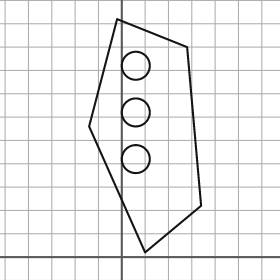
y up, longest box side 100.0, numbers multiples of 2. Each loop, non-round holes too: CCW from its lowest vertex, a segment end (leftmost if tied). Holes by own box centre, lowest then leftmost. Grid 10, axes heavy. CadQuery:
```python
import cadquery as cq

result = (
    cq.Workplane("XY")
    .moveTo(10.0, 2.0)
    .lineTo(34.0, 22.0)
    .lineTo(28.0, 90.0)
    .lineTo(-2.0, 102.0)
    .lineTo(-14.0, 56.0)
    .close()
    .moveTo(6.0, 42.0)
    .circle(6.0)
    .moveTo(6.0, 62.0)
    .circle(6.0)
    .moveTo(6.0, 82.0)
    .circle(6.0)
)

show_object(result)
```